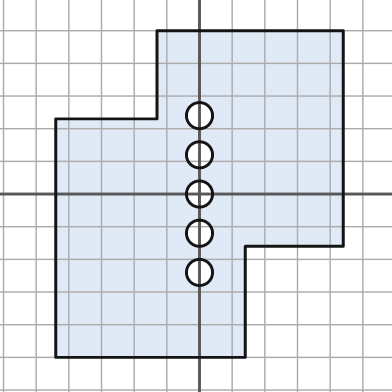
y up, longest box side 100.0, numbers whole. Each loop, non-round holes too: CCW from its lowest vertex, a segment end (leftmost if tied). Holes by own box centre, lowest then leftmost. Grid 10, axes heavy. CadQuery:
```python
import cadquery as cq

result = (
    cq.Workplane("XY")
    .moveTo(-44.0, -50.0)
    .lineTo(14.0, -50.0)
    .lineTo(14.0, -16.0)
    .lineTo(44.0, -16.0)
    .lineTo(44.0, 50.0)
    .lineTo(-13.0, 50.0)
    .lineTo(-13.0, 23.0)
    .lineTo(-44.0, 23.0)
    .close()
    .moveTo(0.0, -24.0)
    .circle(4.0)
    .moveTo(0.0, -12.0)
    .circle(4.0)
    .moveTo(0.0, 0.0)
    .circle(4.0)
    .moveTo(0.0, 12.0)
    .circle(4.0)
    .moveTo(0.0, 24.0)
    .circle(4.0)
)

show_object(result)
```